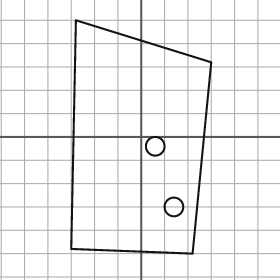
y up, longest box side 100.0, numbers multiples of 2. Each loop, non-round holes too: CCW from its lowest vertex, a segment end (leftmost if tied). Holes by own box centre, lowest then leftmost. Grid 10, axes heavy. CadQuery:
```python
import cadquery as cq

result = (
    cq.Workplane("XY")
    .moveTo(22.0, -50.0)
    .lineTo(30.0, 32.0)
    .lineTo(-28.0, 50.0)
    .lineTo(-30.0, -48.0)
    .close()
    .moveTo(14.0, -30.0)
    .circle(4.0)
    .moveTo(6.0, -4.0)
    .circle(4.0)
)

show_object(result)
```